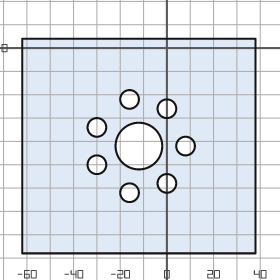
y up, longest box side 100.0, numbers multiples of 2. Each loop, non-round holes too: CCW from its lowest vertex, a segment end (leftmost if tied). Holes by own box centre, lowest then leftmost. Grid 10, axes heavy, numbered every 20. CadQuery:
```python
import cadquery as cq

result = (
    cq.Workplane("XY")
    .moveTo(-62.0, -88.0)
    .lineTo(38.0, -88.0)
    .lineTo(38.0, 4.0)
    .lineTo(-62.0, 4.0)
    .close()
    .moveTo(-16.0, -62.0)
    .circle(4.0)
    .moveTo(0.0, -58.0)
    .circle(4.0)
    .moveTo(-30.0, -50.0)
    .circle(4.0)
    .moveTo(-12.0, -42.0)
    .circle(10.0)
    .moveTo(8.0, -42.0)
    .circle(4.0)
    .moveTo(-30.0, -34.0)
    .circle(4.0)
    .moveTo(0.0, -26.0)
    .circle(4.0)
    .moveTo(-16.0, -22.0)
    .circle(4.0)
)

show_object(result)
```